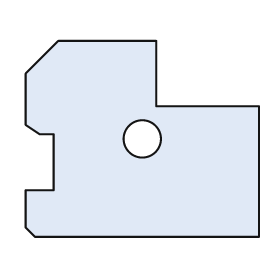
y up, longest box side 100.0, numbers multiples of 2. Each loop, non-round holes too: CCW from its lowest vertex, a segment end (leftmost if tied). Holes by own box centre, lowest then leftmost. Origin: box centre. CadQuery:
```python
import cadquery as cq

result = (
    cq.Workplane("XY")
    .moveTo(-46.0, -42.0)
    .lineTo(50.0, -42.0)
    .lineTo(50.0, 14.0)
    .lineTo(6.0, 14.0)
    .lineTo(6.0, 42.0)
    .lineTo(-36.0, 42.0)
    .lineTo(-50.0, 28.0)
    .lineTo(-50.0, 6.0)
    .lineTo(-44.0, 2.0)
    .lineTo(-38.0, 2.0)
    .lineTo(-38.0, -22.0)
    .lineTo(-50.0, -22.0)
    .lineTo(-50.0, -38.0)
    .close()
    .moveTo(0.0, 0.0)
    .circle(8.0)
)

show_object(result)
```